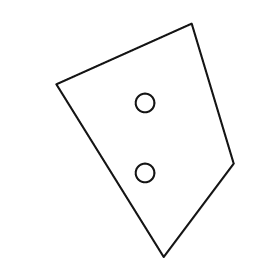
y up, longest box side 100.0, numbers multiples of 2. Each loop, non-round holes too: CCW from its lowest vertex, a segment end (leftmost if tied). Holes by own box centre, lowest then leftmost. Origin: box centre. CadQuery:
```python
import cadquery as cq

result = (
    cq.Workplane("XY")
    .moveTo(8.0, -50.0)
    .lineTo(38.0, -10.0)
    .lineTo(20.0, 50.0)
    .lineTo(-38.0, 24.0)
    .close()
    .moveTo(0.0, -14.0)
    .circle(4.0)
    .moveTo(0.0, 16.0)
    .circle(4.0)
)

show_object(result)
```